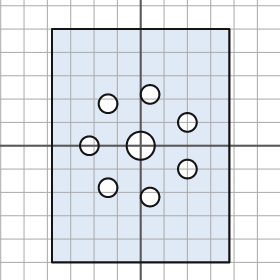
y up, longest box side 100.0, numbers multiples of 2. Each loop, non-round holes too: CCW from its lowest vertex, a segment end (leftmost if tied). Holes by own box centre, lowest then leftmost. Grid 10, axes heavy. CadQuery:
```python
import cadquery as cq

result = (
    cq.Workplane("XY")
    .moveTo(-38.0, -50.0)
    .lineTo(38.0, -50.0)
    .lineTo(38.0, 50.0)
    .lineTo(-38.0, 50.0)
    .close()
    .moveTo(4.0, -22.0)
    .circle(4.0)
    .moveTo(-14.0, -18.0)
    .circle(4.0)
    .moveTo(20.0, -10.0)
    .circle(4.0)
    .moveTo(-22.0, 0.0)
    .circle(4.0)
    .moveTo(0.0, 0.0)
    .circle(6.0)
    .moveTo(20.0, 10.0)
    .circle(4.0)
    .moveTo(-14.0, 18.0)
    .circle(4.0)
    .moveTo(4.0, 22.0)
    .circle(4.0)
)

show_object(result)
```